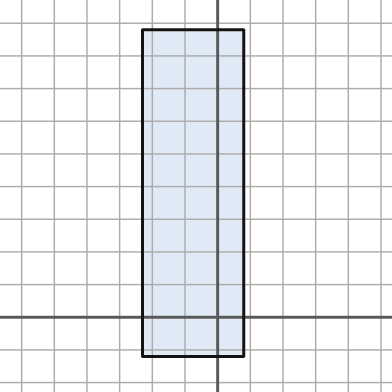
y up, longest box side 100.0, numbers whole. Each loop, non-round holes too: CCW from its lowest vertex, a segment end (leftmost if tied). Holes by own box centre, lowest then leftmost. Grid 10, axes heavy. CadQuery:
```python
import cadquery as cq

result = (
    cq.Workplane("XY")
    .moveTo(-23.0, -12.0)
    .lineTo(8.0, -12.0)
    .lineTo(8.0, 88.0)
    .lineTo(-23.0, 88.0)
    .close()
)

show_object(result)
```